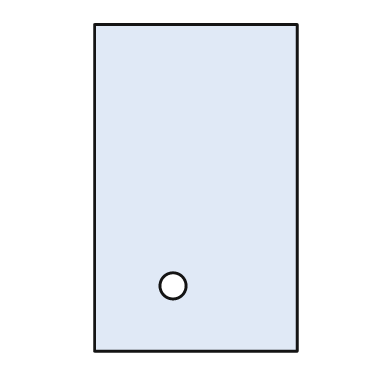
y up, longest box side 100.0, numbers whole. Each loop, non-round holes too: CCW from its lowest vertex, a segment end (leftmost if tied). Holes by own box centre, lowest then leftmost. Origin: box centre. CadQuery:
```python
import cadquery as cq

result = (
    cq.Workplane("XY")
    .moveTo(-31.0, -50.0)
    .lineTo(31.0, -50.0)
    .lineTo(31.0, 50.0)
    .lineTo(-31.0, 50.0)
    .close()
    .moveTo(-7.0, -30.0)
    .circle(4.0)
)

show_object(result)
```